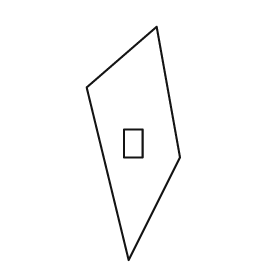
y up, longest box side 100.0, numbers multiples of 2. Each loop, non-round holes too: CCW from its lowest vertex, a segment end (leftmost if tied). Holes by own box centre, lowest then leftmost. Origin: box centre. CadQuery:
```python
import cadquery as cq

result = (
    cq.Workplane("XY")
    .moveTo(-2.0, -50.0)
    .lineTo(20.0, -6.0)
    .lineTo(10.0, 50.0)
    .lineTo(-20.0, 24.0)
    .close()
    .moveTo(-4.0, -6.0)
    .lineTo(4.0, -6.0)
    .lineTo(4.0, 6.0)
    .lineTo(-4.0, 6.0)
    .close()
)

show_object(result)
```